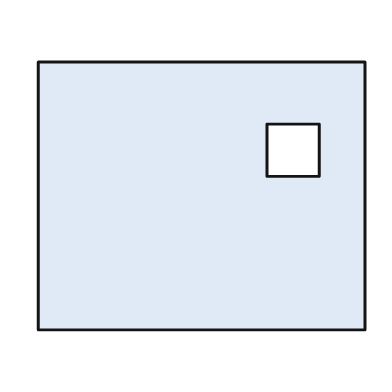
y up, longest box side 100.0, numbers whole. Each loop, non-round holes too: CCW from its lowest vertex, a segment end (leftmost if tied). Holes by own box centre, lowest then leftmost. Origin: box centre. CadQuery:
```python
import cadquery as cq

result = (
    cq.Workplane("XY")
    .moveTo(-50.0, -41.0)
    .lineTo(50.0, -41.0)
    .lineTo(50.0, 41.0)
    .lineTo(-50.0, 41.0)
    .close()
    .moveTo(20.0, 6.0)
    .lineTo(36.0, 6.0)
    .lineTo(36.0, 22.0)
    .lineTo(20.0, 22.0)
    .close()
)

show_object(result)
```